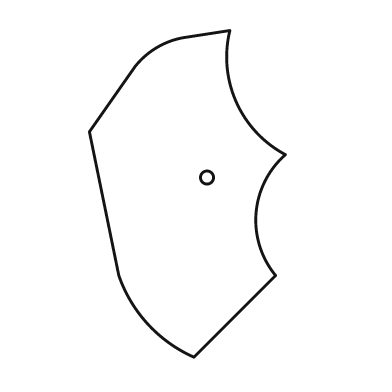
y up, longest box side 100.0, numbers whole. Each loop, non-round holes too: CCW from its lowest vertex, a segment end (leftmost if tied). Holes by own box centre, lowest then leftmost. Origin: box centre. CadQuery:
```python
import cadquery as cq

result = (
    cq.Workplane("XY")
    .moveTo(2.0, -50.0)
    .lineTo(27.0, -25.0)
    .threePointArc((21.0, -6.0), (30.0, 12.0))
    .threePointArc((15.0, 28.0), (13.0, 50.0))
    .lineTo(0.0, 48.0)
    .threePointArc((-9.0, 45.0), (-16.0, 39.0))
    .lineTo(-30.0, 19.0)
    .lineTo(-21.0, -25.0)
    .threePointArc((-12.0, -40.0), (2.0, -50.0))
    .close()
    .moveTo(6.0, 5.0)
    .circle(2.0)
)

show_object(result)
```